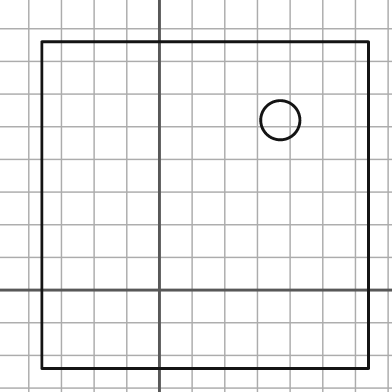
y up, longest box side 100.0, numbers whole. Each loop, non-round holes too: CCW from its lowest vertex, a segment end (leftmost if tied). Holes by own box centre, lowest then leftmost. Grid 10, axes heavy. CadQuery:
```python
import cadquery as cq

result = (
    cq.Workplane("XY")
    .moveTo(-36.0, -24.0)
    .lineTo(64.0, -24.0)
    .lineTo(64.0, 76.0)
    .lineTo(-36.0, 76.0)
    .close()
    .moveTo(37.0, 52.0)
    .circle(6.0)
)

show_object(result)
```